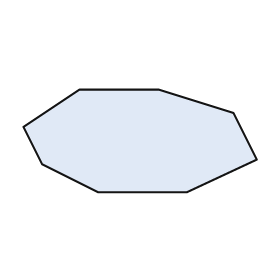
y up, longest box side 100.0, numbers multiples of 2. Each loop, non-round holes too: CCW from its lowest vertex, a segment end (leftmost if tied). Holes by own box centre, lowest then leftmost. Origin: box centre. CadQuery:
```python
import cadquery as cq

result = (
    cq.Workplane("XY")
    .moveTo(-18.0, -22.0)
    .lineTo(20.0, -22.0)
    .lineTo(50.0, -8.0)
    .lineTo(40.0, 12.0)
    .lineTo(8.0, 22.0)
    .lineTo(-26.0, 22.0)
    .lineTo(-50.0, 6.0)
    .lineTo(-42.0, -10.0)
    .close()
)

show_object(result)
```